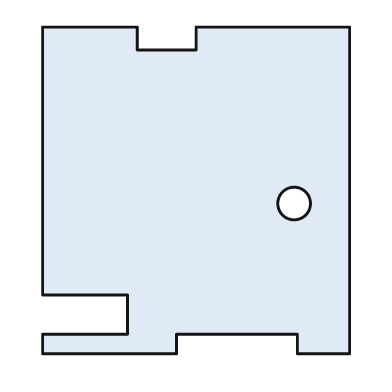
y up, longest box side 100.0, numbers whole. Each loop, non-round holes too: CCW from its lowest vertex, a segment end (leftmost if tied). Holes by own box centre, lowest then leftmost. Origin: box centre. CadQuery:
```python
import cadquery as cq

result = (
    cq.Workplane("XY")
    .moveTo(-47.0, -50.0)
    .lineTo(-6.0, -50.0)
    .lineTo(-6.0, -44.0)
    .lineTo(31.0, -44.0)
    .lineTo(31.0, -50.0)
    .lineTo(47.0, -50.0)
    .lineTo(47.0, 50.0)
    .lineTo(0.0, 50.0)
    .lineTo(0.0, 43.0)
    .lineTo(-18.0, 43.0)
    .lineTo(-18.0, 50.0)
    .lineTo(-47.0, 50.0)
    .lineTo(-47.0, -32.0)
    .lineTo(-21.0, -32.0)
    .lineTo(-21.0, -44.0)
    .lineTo(-47.0, -44.0)
    .close()
    .moveTo(30.0, -4.0)
    .circle(5.0)
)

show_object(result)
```